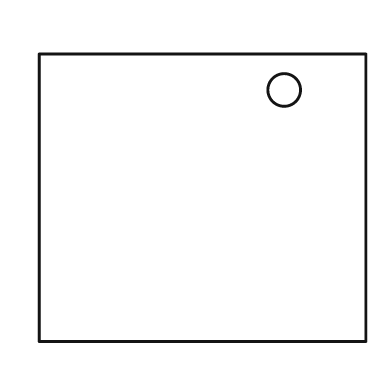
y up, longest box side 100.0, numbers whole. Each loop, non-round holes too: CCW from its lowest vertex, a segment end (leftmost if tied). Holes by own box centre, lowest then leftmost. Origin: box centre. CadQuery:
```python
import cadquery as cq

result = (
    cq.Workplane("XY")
    .moveTo(-50.0, -44.0)
    .lineTo(50.0, -44.0)
    .lineTo(50.0, 44.0)
    .lineTo(-50.0, 44.0)
    .close()
    .moveTo(25.0, 33.0)
    .circle(5.0)
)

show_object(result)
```